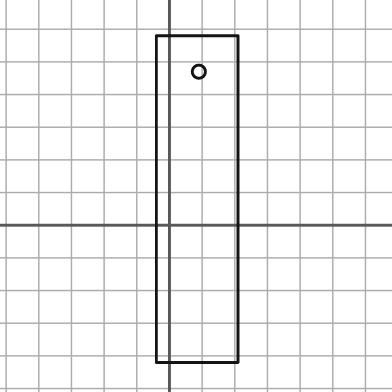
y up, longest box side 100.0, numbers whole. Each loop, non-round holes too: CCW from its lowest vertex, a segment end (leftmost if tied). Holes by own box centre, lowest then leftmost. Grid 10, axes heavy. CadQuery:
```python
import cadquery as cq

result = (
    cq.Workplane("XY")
    .moveTo(-4.0, -42.0)
    .lineTo(21.0, -42.0)
    .lineTo(21.0, 58.0)
    .lineTo(-4.0, 58.0)
    .close()
    .moveTo(9.0, 47.0)
    .circle(2.0)
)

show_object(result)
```